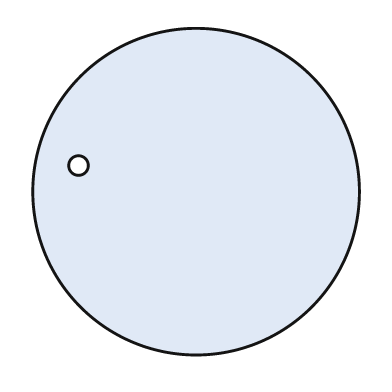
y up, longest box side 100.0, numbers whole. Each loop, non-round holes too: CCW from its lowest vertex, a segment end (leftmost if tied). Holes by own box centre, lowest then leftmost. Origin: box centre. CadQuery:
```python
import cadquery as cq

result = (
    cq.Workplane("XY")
    .moveTo(0.0, 0.0)
    .circle(50.0)
    .moveTo(-36.0, 8.0)
    .circle(3.0)
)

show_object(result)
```